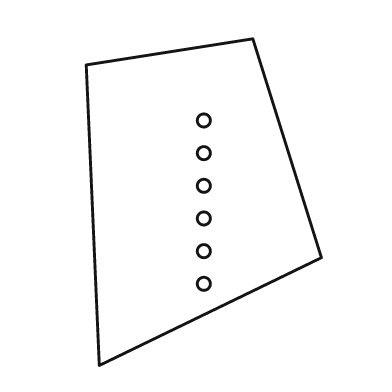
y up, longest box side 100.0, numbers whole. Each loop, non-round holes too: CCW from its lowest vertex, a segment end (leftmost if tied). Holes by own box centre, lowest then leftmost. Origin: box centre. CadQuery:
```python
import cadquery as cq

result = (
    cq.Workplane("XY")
    .moveTo(-32.0, -50.0)
    .lineTo(36.0, -17.0)
    .lineTo(15.0, 50.0)
    .lineTo(-36.0, 42.0)
    .close()
    .moveTo(0.0, -25.0)
    .circle(2.0)
    .moveTo(0.0, -15.0)
    .circle(2.0)
    .moveTo(0.0, -5.0)
    .circle(2.0)
    .moveTo(0.0, 5.0)
    .circle(2.0)
    .moveTo(0.0, 15.0)
    .circle(2.0)
    .moveTo(0.0, 25.0)
    .circle(2.0)
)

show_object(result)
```